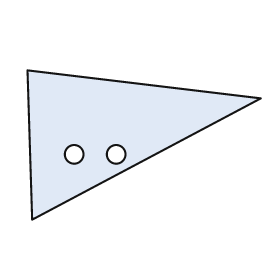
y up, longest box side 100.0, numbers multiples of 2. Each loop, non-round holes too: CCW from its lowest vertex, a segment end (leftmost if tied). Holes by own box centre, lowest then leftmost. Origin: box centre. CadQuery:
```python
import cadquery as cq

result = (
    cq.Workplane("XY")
    .moveTo(-48.0, -32.0)
    .lineTo(50.0, 20.0)
    .lineTo(-50.0, 32.0)
    .close()
    .moveTo(-30.0, -4.0)
    .circle(4.0)
    .moveTo(-12.0, -4.0)
    .circle(4.0)
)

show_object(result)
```